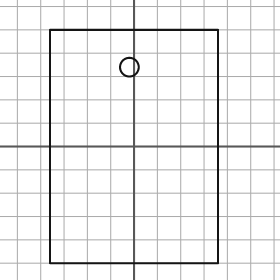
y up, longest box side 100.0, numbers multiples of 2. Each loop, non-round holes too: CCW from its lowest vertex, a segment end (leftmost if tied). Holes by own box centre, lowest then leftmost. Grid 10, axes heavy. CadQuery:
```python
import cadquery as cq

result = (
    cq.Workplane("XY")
    .moveTo(-36.0, -50.0)
    .lineTo(36.0, -50.0)
    .lineTo(36.0, 50.0)
    .lineTo(-36.0, 50.0)
    .close()
    .moveTo(-2.0, 34.0)
    .circle(4.0)
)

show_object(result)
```